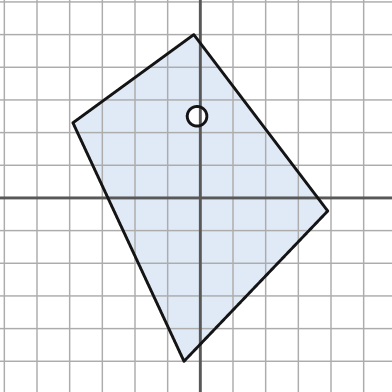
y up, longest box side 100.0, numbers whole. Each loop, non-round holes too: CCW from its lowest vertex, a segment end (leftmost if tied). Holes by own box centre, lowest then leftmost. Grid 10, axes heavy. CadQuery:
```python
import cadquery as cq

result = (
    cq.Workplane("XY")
    .moveTo(-5.0, -50.0)
    .lineTo(39.0, -4.0)
    .lineTo(-2.0, 50.0)
    .lineTo(-39.0, 23.0)
    .close()
    .moveTo(-1.0, 25.0)
    .circle(3.0)
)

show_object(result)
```